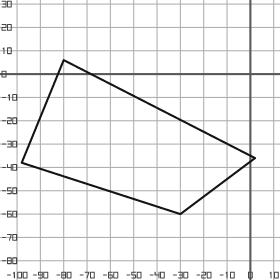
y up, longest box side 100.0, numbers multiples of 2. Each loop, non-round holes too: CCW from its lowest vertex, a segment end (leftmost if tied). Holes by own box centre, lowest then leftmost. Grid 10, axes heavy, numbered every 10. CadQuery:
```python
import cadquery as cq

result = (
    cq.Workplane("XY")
    .moveTo(-30.0, -60.0)
    .lineTo(2.0, -36.0)
    .lineTo(-80.0, 6.0)
    .lineTo(-98.0, -38.0)
    .close()
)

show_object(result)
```